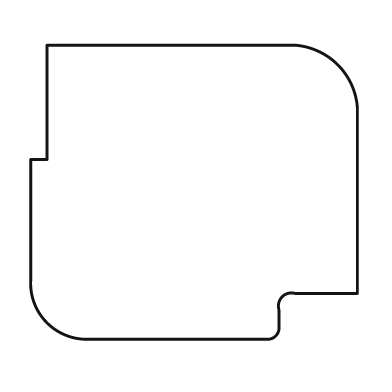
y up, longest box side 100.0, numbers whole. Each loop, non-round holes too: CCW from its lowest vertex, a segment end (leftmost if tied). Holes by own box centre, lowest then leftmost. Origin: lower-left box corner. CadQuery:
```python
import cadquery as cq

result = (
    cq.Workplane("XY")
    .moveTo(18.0, 0.0)
    .lineTo(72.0, 0.0)
    .threePointArc((75.0, 1.0), (76.0, 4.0))
    .lineTo(76.0, 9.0)
    .threePointArc((77.0, 13.0), (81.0, 14.0))
    .lineTo(100.0, 14.0)
    .lineTo(100.0, 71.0)
    .threePointArc((94.0, 84.0), (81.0, 90.0))
    .lineTo(5.0, 90.0)
    .lineTo(5.0, 55.0)
    .lineTo(0.0, 55.0)
    .lineTo(0.0, 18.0)
    .threePointArc((5.0, 5.0), (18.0, 0.0))
    .close()
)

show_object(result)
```